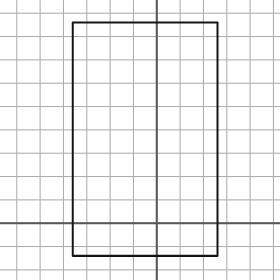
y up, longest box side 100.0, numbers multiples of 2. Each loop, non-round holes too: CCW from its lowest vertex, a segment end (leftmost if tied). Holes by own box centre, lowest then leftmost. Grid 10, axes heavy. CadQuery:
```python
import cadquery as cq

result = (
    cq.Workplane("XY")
    .moveTo(-36.0, -14.0)
    .lineTo(26.0, -14.0)
    .lineTo(26.0, 86.0)
    .lineTo(-36.0, 86.0)
    .close()
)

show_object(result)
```